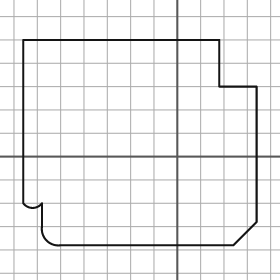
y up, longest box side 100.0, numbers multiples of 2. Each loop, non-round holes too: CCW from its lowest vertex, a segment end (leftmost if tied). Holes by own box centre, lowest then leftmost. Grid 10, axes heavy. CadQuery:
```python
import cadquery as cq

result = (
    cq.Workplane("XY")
    .moveTo(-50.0, -38.0)
    .lineTo(24.0, -38.0)
    .lineTo(34.0, -28.0)
    .lineTo(34.0, 30.0)
    .lineTo(18.0, 30.0)
    .lineTo(18.0, 50.0)
    .lineTo(-66.0, 50.0)
    .lineTo(-66.0, -20.0)
    .threePointArc((-62.0, -22.0), (-58.0, -20.0))
    .lineTo(-58.0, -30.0)
    .threePointArc((-56.0, -36.0), (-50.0, -38.0))
    .close()
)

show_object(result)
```